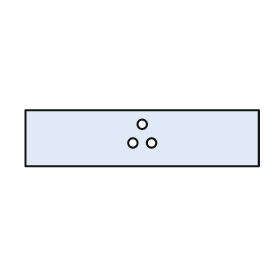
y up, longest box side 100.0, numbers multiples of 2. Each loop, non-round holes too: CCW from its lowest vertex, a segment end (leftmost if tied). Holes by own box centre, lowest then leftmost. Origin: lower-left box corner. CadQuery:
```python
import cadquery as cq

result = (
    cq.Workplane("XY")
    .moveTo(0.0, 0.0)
    .lineTo(100.0, 0.0)
    .lineTo(100.0, 24.0)
    .lineTo(0.0, 24.0)
    .close()
    .moveTo(46.0, 10.0)
    .circle(2.0)
    .moveTo(54.0, 10.0)
    .circle(2.0)
    .moveTo(50.0, 18.0)
    .circle(2.0)
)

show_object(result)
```